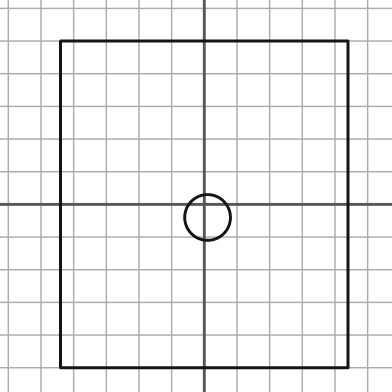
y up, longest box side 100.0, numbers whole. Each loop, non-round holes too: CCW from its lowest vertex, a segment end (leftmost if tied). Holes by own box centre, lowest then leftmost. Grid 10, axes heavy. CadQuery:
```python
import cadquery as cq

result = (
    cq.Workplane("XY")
    .moveTo(-44.0, -50.0)
    .lineTo(44.0, -50.0)
    .lineTo(44.0, 50.0)
    .lineTo(-44.0, 50.0)
    .close()
    .moveTo(1.0, -4.0)
    .circle(7.0)
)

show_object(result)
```